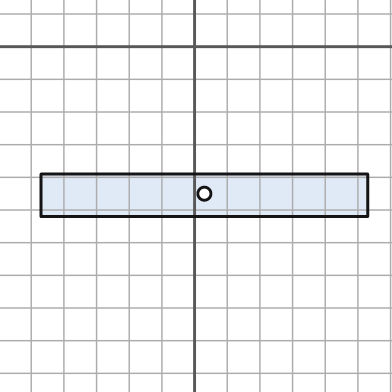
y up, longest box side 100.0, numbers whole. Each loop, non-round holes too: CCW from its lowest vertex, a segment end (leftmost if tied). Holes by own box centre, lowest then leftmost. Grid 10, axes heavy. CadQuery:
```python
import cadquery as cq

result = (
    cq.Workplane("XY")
    .moveTo(-47.0, -52.0)
    .lineTo(53.0, -52.0)
    .lineTo(53.0, -39.0)
    .lineTo(-47.0, -39.0)
    .close()
    .moveTo(3.0, -45.0)
    .circle(2.0)
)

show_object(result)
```